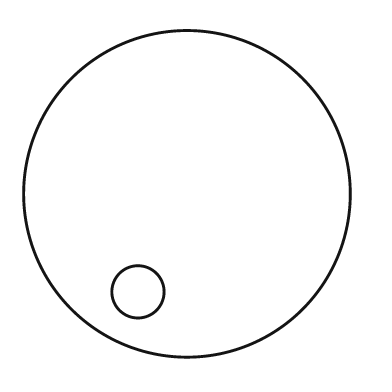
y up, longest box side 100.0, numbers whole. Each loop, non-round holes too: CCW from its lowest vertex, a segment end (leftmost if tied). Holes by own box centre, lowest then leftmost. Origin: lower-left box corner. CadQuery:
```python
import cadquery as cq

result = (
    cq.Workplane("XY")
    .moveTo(50.0, 50.0)
    .circle(50.0)
    .moveTo(35.0, 20.0)
    .circle(8.0)
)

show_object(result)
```